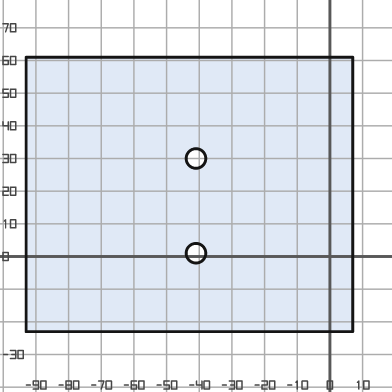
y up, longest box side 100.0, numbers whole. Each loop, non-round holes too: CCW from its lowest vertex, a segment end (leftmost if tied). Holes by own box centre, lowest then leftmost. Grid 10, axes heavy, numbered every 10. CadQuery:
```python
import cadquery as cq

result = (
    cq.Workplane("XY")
    .moveTo(-93.0, -23.0)
    .lineTo(7.0, -23.0)
    .lineTo(7.0, 61.0)
    .lineTo(-93.0, 61.0)
    .close()
    .moveTo(-41.0, 1.0)
    .circle(3.0)
    .moveTo(-41.0, 30.0)
    .circle(3.0)
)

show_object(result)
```